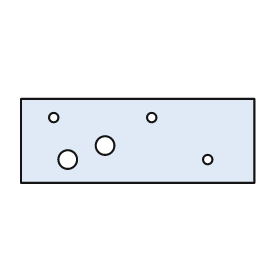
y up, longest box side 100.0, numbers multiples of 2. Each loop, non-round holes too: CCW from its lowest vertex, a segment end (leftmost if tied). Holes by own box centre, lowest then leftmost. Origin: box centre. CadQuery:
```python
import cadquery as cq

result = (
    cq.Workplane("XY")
    .moveTo(-50.0, -18.0)
    .lineTo(50.0, -18.0)
    .lineTo(50.0, 18.0)
    .lineTo(-50.0, 18.0)
    .close()
    .moveTo(-30.0, -8.0)
    .circle(4.0)
    .moveTo(30.0, -8.0)
    .circle(2.0)
    .moveTo(-14.0, -2.0)
    .circle(4.0)
    .moveTo(-36.0, 10.0)
    .circle(2.0)
    .moveTo(6.0, 10.0)
    .circle(2.0)
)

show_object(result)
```